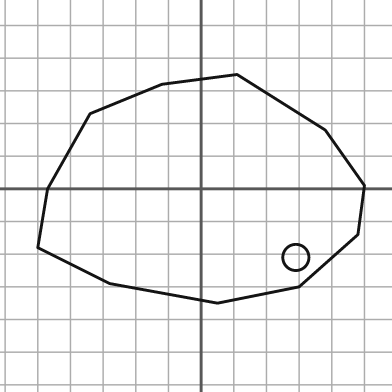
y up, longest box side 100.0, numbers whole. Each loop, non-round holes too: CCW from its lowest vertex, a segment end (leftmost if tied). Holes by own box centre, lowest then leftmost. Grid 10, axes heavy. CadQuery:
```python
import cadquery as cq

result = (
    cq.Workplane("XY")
    .moveTo(5.0, -35.0)
    .lineTo(30.0, -30.0)
    .lineTo(48.0, -14.0)
    .lineTo(50.0, 1.0)
    .lineTo(38.0, 18.0)
    .lineTo(11.0, 35.0)
    .lineTo(-12.0, 32.0)
    .lineTo(-34.0, 23.0)
    .lineTo(-47.0, 0.0)
    .lineTo(-50.0, -18.0)
    .lineTo(-28.0, -29.0)
    .close()
    .moveTo(29.0, -21.0)
    .circle(4.0)
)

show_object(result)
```